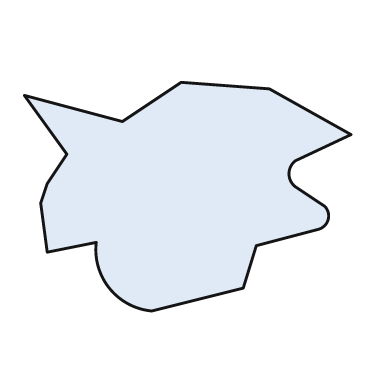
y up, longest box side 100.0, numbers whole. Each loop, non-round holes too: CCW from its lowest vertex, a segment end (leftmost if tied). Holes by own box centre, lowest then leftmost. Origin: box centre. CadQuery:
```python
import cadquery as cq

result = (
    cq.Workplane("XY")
    .moveTo(-11.0, -35.0)
    .lineTo(17.0, -28.0)
    .lineTo(21.0, -15.0)
    .lineTo(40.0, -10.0)
    .threePointArc((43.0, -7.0), (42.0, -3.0))
    .lineTo(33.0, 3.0)
    .threePointArc((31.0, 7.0), (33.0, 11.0))
    .lineTo(50.0, 19.0)
    .lineTo(25.0, 33.0)
    .lineTo(-2.0, 35.0)
    .lineTo(-20.0, 23.0)
    .lineTo(-50.0, 31.0)
    .lineTo(-37.0, 13.0)
    .lineTo(-43.0, 4.0)
    .lineTo(-45.0, -2.0)
    .lineTo(-43.0, -17.0)
    .lineTo(-28.0, -14.0)
    .threePointArc((-24.0, -28.0), (-11.0, -35.0))
    .close()
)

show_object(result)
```